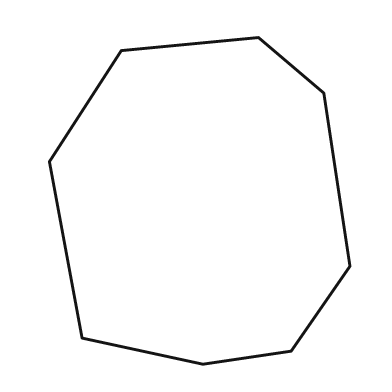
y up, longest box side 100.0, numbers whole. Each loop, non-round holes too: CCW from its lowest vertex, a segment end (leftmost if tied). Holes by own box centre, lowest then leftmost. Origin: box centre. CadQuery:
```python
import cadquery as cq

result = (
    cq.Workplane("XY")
    .moveTo(1.0, -50.0)
    .lineTo(28.0, -46.0)
    .lineTo(46.0, -20.0)
    .lineTo(38.0, 33.0)
    .lineTo(18.0, 50.0)
    .lineTo(-24.0, 46.0)
    .lineTo(-46.0, 12.0)
    .lineTo(-36.0, -42.0)
    .close()
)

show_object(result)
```